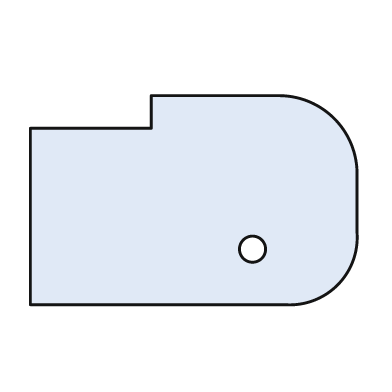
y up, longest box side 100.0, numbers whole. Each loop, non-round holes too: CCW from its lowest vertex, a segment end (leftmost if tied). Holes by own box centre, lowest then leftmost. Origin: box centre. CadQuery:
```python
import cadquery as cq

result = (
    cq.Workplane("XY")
    .moveTo(-50.0, -32.0)
    .lineTo(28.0, -32.0)
    .threePointArc((44.0, -26.0), (50.0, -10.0))
    .lineTo(50.0, 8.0)
    .threePointArc((43.0, 25.0), (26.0, 32.0))
    .lineTo(-13.0, 32.0)
    .lineTo(-13.0, 22.0)
    .lineTo(-50.0, 22.0)
    .close()
    .moveTo(18.0, -15.0)
    .circle(4.0)
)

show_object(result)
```